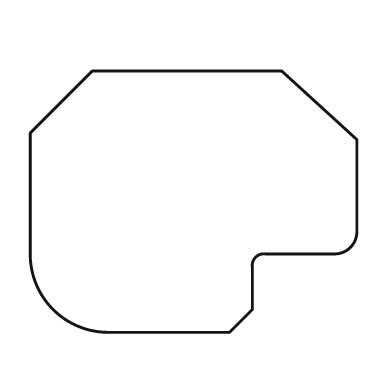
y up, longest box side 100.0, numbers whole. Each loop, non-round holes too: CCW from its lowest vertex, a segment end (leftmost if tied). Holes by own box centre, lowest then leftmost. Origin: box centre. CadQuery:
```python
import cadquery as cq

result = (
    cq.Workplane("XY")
    .moveTo(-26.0, -40.0)
    .lineTo(11.0, -40.0)
    .lineTo(18.0, -33.0)
    .lineTo(18.0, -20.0)
    .threePointArc((19.0, -17.0), (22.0, -16.0))
    .lineTo(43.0, -16.0)
    .threePointArc((48.0, -14.0), (50.0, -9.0))
    .lineTo(50.0, 19.0)
    .lineTo(27.0, 40.0)
    .lineTo(-31.0, 40.0)
    .lineTo(-50.0, 21.0)
    .lineTo(-50.0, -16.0)
    .threePointArc((-43.0, -33.0), (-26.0, -40.0))
    .close()
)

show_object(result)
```